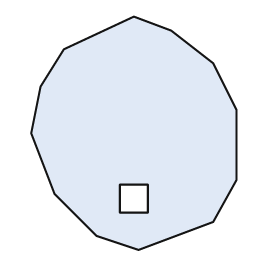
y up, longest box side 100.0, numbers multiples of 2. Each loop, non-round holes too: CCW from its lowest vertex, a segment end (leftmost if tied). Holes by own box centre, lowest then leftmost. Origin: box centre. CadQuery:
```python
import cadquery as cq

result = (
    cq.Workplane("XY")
    .moveTo(2.0, -50.0)
    .lineTo(34.0, -38.0)
    .lineTo(44.0, -20.0)
    .lineTo(44.0, 10.0)
    .lineTo(34.0, 30.0)
    .lineTo(16.0, 44.0)
    .lineTo(0.0, 50.0)
    .lineTo(-30.0, 36.0)
    .lineTo(-40.0, 20.0)
    .lineTo(-44.0, 0.0)
    .lineTo(-34.0, -26.0)
    .lineTo(-16.0, -44.0)
    .close()
    .moveTo(-6.0, -34.0)
    .lineTo(6.0, -34.0)
    .lineTo(6.0, -22.0)
    .lineTo(-6.0, -22.0)
    .close()
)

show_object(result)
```